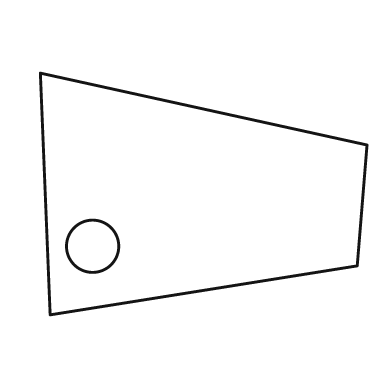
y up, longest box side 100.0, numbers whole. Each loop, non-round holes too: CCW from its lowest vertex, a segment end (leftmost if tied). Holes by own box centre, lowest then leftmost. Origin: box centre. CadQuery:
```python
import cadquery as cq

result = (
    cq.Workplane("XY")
    .moveTo(-47.0, -37.0)
    .lineTo(47.0, -22.0)
    .lineTo(50.0, 15.0)
    .lineTo(-50.0, 37.0)
    .close()
    .moveTo(-34.0, -16.0)
    .circle(8.0)
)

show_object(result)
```